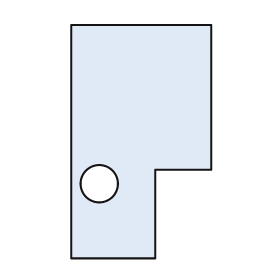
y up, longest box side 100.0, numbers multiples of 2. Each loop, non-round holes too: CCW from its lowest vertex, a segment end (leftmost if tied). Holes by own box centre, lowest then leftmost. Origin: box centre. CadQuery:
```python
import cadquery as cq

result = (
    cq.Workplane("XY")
    .moveTo(-30.0, -50.0)
    .lineTo(6.0, -50.0)
    .lineTo(6.0, -12.0)
    .lineTo(30.0, -12.0)
    .lineTo(30.0, 50.0)
    .lineTo(-30.0, 50.0)
    .close()
    .moveTo(-18.0, -18.0)
    .circle(8.0)
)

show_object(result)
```